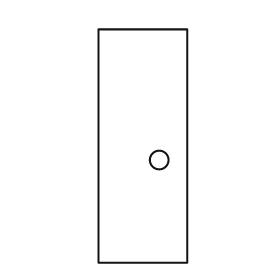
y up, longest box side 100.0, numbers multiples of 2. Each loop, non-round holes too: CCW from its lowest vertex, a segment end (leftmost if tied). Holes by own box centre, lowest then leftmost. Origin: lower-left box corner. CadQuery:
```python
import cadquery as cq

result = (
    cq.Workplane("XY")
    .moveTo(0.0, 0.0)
    .lineTo(38.0, 0.0)
    .lineTo(38.0, 100.0)
    .lineTo(0.0, 100.0)
    .close()
    .moveTo(26.0, 44.0)
    .circle(4.0)
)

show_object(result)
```